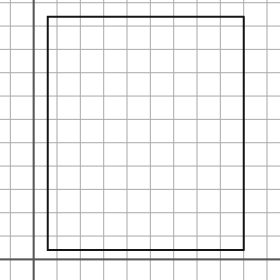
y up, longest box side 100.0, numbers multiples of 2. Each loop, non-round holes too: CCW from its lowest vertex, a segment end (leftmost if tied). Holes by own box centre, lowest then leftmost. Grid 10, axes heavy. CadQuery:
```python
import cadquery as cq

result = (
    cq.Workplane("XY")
    .moveTo(6.0, 4.0)
    .lineTo(90.0, 4.0)
    .lineTo(90.0, 104.0)
    .lineTo(6.0, 104.0)
    .close()
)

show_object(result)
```